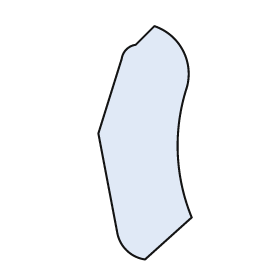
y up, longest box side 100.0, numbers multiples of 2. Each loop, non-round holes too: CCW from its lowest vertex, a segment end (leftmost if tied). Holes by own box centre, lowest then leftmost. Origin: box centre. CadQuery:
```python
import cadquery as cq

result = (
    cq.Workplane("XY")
    .moveTo(0.0, -50.0)
    .lineTo(20.0, -32.0)
    .threePointArc((14.0, -4.0), (18.0, 24.0))
    .threePointArc((16.0, 40.0), (4.0, 50.0))
    .lineTo(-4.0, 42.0)
    .threePointArc((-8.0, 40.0), (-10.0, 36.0))
    .lineTo(-20.0, 4.0)
    .lineTo(-12.0, -38.0)
    .threePointArc((-8.0, -46.0), (0.0, -50.0))
    .close()
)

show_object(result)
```